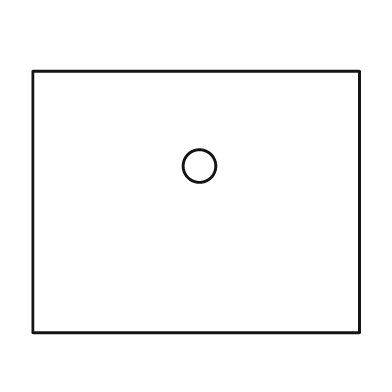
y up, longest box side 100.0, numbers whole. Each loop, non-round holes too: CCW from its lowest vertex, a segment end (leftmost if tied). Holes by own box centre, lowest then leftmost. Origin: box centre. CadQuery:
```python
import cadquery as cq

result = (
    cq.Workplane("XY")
    .moveTo(-50.0, -40.0)
    .lineTo(50.0, -40.0)
    .lineTo(50.0, 40.0)
    .lineTo(-50.0, 40.0)
    .close()
    .moveTo(1.0, 11.0)
    .circle(5.0)
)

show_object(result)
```